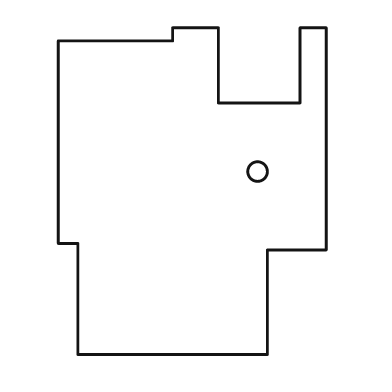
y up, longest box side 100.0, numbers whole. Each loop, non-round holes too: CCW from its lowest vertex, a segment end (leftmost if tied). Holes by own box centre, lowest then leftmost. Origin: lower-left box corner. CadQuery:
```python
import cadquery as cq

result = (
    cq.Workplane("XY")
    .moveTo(6.0, 0.0)
    .lineTo(64.0, 0.0)
    .lineTo(64.0, 32.0)
    .lineTo(82.0, 32.0)
    .lineTo(82.0, 100.0)
    .lineTo(74.0, 100.0)
    .lineTo(74.0, 77.0)
    .lineTo(49.0, 77.0)
    .lineTo(49.0, 100.0)
    .lineTo(35.0, 100.0)
    .lineTo(35.0, 96.0)
    .lineTo(0.0, 96.0)
    .lineTo(0.0, 34.0)
    .lineTo(6.0, 34.0)
    .close()
    .moveTo(61.0, 56.0)
    .circle(3.0)
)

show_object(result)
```